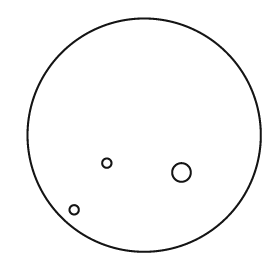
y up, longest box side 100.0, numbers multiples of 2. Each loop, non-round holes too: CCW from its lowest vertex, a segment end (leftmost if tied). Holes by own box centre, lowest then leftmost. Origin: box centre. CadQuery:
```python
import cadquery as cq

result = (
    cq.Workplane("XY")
    .moveTo(0.0, 0.0)
    .circle(50.0)
    .moveTo(-30.0, -32.0)
    .circle(2.0)
    .moveTo(16.0, -16.0)
    .circle(4.0)
    .moveTo(-16.0, -12.0)
    .circle(2.0)
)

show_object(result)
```